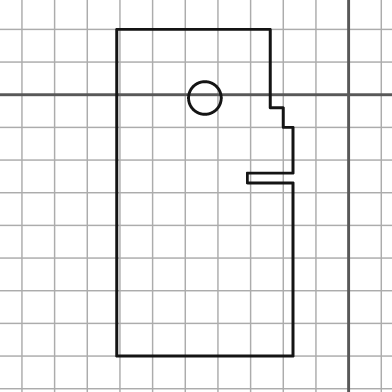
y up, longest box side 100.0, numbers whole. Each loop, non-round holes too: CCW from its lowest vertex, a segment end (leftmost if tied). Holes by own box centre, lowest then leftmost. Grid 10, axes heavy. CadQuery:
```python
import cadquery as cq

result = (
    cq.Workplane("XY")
    .moveTo(-71.0, -80.0)
    .lineTo(-17.0, -80.0)
    .lineTo(-17.0, -27.0)
    .lineTo(-31.0, -27.0)
    .lineTo(-31.0, -24.0)
    .lineTo(-17.0, -24.0)
    .lineTo(-17.0, -10.0)
    .lineTo(-20.0, -10.0)
    .lineTo(-20.0, -4.0)
    .lineTo(-24.0, -4.0)
    .lineTo(-24.0, 20.0)
    .lineTo(-71.0, 20.0)
    .close()
    .moveTo(-44.0, -1.0)
    .circle(5.0)
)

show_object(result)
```